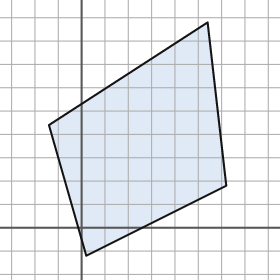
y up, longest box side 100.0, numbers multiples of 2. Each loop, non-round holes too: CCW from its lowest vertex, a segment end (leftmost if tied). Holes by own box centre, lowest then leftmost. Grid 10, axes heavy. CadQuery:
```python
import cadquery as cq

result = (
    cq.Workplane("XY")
    .moveTo(2.0, -12.0)
    .lineTo(62.0, 18.0)
    .lineTo(54.0, 88.0)
    .lineTo(-14.0, 44.0)
    .close()
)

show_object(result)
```